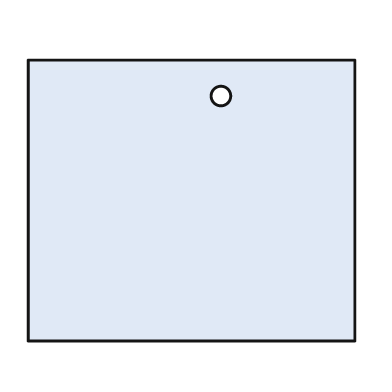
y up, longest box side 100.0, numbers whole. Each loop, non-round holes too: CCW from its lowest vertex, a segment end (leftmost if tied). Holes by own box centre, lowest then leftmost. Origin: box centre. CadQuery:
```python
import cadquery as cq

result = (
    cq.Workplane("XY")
    .moveTo(-50.0, -43.0)
    .lineTo(50.0, -43.0)
    .lineTo(50.0, 43.0)
    .lineTo(-50.0, 43.0)
    .close()
    .moveTo(9.0, 32.0)
    .circle(3.0)
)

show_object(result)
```